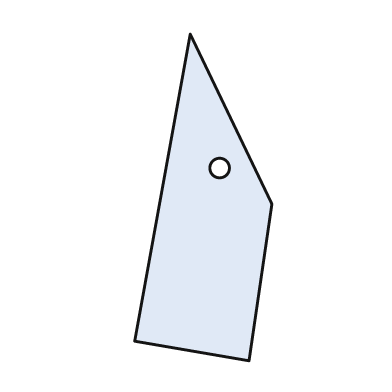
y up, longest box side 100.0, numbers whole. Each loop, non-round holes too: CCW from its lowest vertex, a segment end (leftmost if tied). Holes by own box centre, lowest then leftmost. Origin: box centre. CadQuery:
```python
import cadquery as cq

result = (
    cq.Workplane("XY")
    .moveTo(14.0, -50.0)
    .lineTo(21.0, -2.0)
    .lineTo(-4.0, 50.0)
    .lineTo(-21.0, -44.0)
    .close()
    .moveTo(5.0, 9.0)
    .circle(3.0)
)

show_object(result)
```